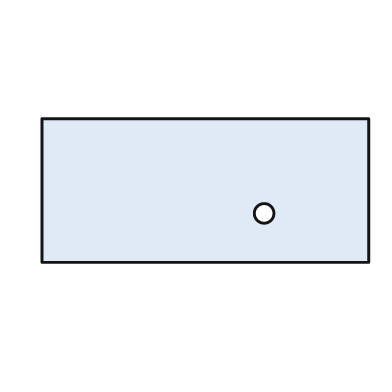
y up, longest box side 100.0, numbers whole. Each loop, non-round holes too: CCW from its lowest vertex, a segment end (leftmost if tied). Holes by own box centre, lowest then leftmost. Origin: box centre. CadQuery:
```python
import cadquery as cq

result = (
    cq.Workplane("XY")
    .moveTo(-50.0, -22.0)
    .lineTo(50.0, -22.0)
    .lineTo(50.0, 22.0)
    .lineTo(-50.0, 22.0)
    .close()
    .moveTo(18.0, -7.0)
    .circle(3.0)
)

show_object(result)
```